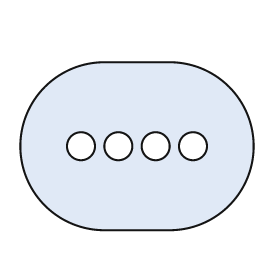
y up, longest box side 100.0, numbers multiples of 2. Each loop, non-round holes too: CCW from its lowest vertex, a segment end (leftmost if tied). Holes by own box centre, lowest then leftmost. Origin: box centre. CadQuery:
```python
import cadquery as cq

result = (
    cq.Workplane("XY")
    .moveTo(-14.0, -36.0)
    .lineTo(14.0, -36.0)
    .threePointArc((50.0, 0.0), (14.0, 36.0))
    .lineTo(-14.0, 36.0)
    .threePointArc((-50.0, 0.0), (-14.0, -36.0))
    .close()
    .moveTo(-24.0, 0.0)
    .circle(6.0)
    .moveTo(-8.0, 0.0)
    .circle(6.0)
    .moveTo(8.0, 0.0)
    .circle(6.0)
    .moveTo(24.0, 0.0)
    .circle(6.0)
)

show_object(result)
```